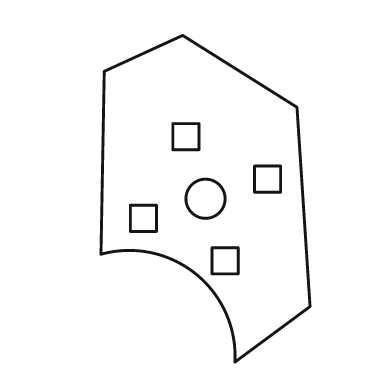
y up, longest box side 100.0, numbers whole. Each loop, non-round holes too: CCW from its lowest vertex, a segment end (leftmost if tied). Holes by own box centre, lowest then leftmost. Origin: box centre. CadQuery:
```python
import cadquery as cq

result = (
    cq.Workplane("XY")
    .moveTo(9.0, -50.0)
    .lineTo(32.0, -33.0)
    .lineTo(28.0, 28.0)
    .lineTo(-7.0, 50.0)
    .lineTo(-31.0, 39.0)
    .lineTo(-32.0, -17.0)
    .threePointArc((-3.0, -23.0), (9.0, -50.0))
    .close()
    .moveTo(2.0, -23.0)
    .lineTo(10.0, -23.0)
    .lineTo(10.0, -15.0)
    .lineTo(2.0, -15.0)
    .close()
    .moveTo(-23.0, -10.0)
    .lineTo(-15.0, -10.0)
    .lineTo(-15.0, -2.0)
    .lineTo(-23.0, -2.0)
    .close()
    .moveTo(0.0, 0.0)
    .circle(6.0)
    .moveTo(15.0, 2.0)
    .lineTo(23.0, 2.0)
    .lineTo(23.0, 10.0)
    .lineTo(15.0, 10.0)
    .close()
    .moveTo(-10.0, 15.0)
    .lineTo(-2.0, 15.0)
    .lineTo(-2.0, 23.0)
    .lineTo(-10.0, 23.0)
    .close()
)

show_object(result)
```